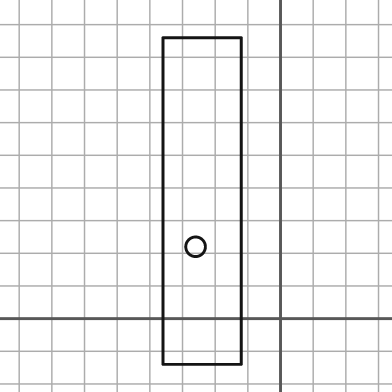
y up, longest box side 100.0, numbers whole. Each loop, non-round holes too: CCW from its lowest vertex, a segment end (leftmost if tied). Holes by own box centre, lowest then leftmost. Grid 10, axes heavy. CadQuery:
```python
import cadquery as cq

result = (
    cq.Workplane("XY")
    .moveTo(-36.0, -14.0)
    .lineTo(-12.0, -14.0)
    .lineTo(-12.0, 86.0)
    .lineTo(-36.0, 86.0)
    .close()
    .moveTo(-26.0, 22.0)
    .circle(3.0)
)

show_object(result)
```